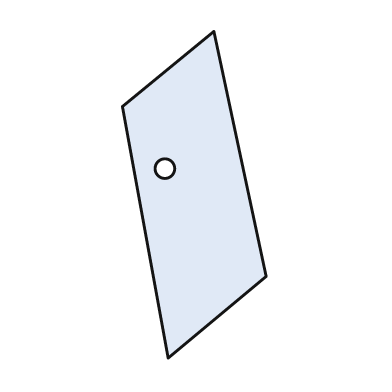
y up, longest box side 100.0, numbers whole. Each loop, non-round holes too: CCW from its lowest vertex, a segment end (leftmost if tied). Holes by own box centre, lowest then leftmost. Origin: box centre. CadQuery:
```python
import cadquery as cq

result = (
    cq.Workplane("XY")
    .moveTo(-8.0, -50.0)
    .lineTo(22.0, -25.0)
    .lineTo(6.0, 50.0)
    .lineTo(-22.0, 27.0)
    .close()
    .moveTo(-9.0, 8.0)
    .circle(3.0)
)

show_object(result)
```